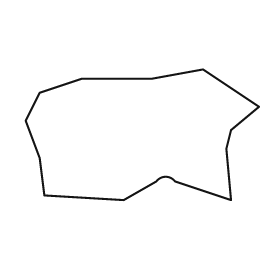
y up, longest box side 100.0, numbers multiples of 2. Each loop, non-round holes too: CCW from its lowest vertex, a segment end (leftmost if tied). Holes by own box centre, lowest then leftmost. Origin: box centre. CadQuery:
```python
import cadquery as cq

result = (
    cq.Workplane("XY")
    .moveTo(-8.0, -28.0)
    .lineTo(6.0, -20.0)
    .threePointArc((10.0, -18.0), (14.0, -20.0))
    .lineTo(38.0, -28.0)
    .lineTo(36.0, -6.0)
    .lineTo(38.0, 2.0)
    .lineTo(50.0, 12.0)
    .lineTo(26.0, 28.0)
    .lineTo(4.0, 24.0)
    .lineTo(-26.0, 24.0)
    .lineTo(-44.0, 18.0)
    .lineTo(-50.0, 6.0)
    .lineTo(-44.0, -10.0)
    .lineTo(-42.0, -26.0)
    .close()
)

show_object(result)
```